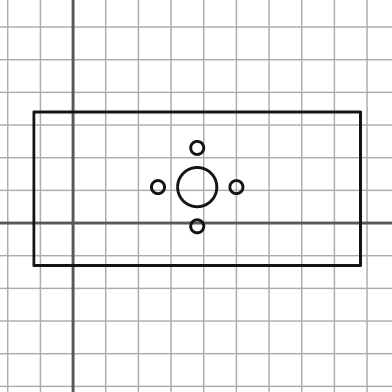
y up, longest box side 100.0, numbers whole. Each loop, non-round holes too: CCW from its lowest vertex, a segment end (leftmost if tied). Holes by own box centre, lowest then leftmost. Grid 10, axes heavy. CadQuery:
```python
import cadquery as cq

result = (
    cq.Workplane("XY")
    .moveTo(-12.0, -13.0)
    .lineTo(88.0, -13.0)
    .lineTo(88.0, 34.0)
    .lineTo(-12.0, 34.0)
    .close()
    .moveTo(38.0, -1.0)
    .circle(2.0)
    .moveTo(26.0, 11.0)
    .circle(2.0)
    .moveTo(38.0, 11.0)
    .circle(6.0)
    .moveTo(50.0, 11.0)
    .circle(2.0)
    .moveTo(38.0, 23.0)
    .circle(2.0)
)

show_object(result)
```